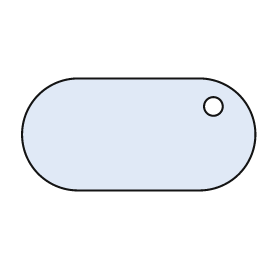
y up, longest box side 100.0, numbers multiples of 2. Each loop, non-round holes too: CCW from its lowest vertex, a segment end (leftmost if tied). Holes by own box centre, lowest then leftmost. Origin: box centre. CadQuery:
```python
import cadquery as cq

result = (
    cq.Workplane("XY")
    .moveTo(-26.0, -24.0)
    .lineTo(26.0, -24.0)
    .threePointArc((50.0, 0.0), (26.0, 24.0))
    .lineTo(-26.0, 24.0)
    .threePointArc((-50.0, 0.0), (-26.0, -24.0))
    .close()
    .moveTo(32.0, 12.0)
    .circle(4.0)
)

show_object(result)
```